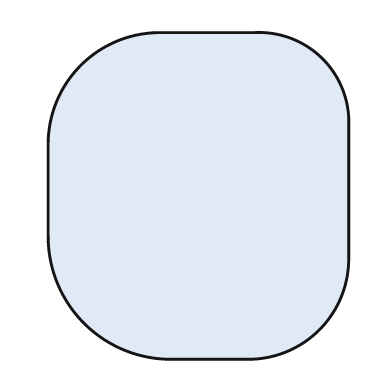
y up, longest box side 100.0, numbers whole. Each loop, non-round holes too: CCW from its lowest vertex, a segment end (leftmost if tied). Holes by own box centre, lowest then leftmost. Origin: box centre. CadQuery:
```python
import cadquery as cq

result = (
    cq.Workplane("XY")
    .moveTo(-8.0, -50.0)
    .lineTo(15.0, -50.0)
    .threePointArc((37.0, -41.0), (46.0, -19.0))
    .lineTo(46.0, 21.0)
    .threePointArc((38.0, 42.0), (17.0, 50.0))
    .lineTo(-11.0, 50.0)
    .threePointArc((-36.0, 40.0), (-46.0, 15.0))
    .lineTo(-46.0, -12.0)
    .threePointArc((-35.0, -39.0), (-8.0, -50.0))
    .close()
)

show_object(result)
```